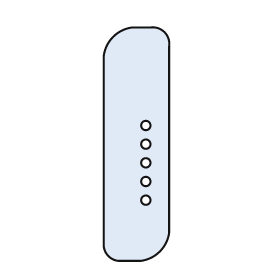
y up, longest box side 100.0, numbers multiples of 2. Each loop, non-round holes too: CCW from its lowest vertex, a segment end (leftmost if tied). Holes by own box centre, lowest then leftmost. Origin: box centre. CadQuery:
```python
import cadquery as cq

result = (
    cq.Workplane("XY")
    .moveTo(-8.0, -50.0)
    .lineTo(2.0, -50.0)
    .threePointArc((10.0, -46.0), (14.0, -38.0))
    .lineTo(14.0, 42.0)
    .threePointArc((12.0, 48.0), (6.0, 50.0))
    .lineTo(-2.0, 50.0)
    .threePointArc((-10.0, 46.0), (-14.0, 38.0))
    .lineTo(-14.0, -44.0)
    .threePointArc((-12.0, -48.0), (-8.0, -50.0))
    .close()
    .moveTo(4.0, -24.0)
    .circle(2.0)
    .moveTo(4.0, -16.0)
    .circle(2.0)
    .moveTo(4.0, -8.0)
    .circle(2.0)
    .moveTo(4.0, 0.0)
    .circle(2.0)
    .moveTo(4.0, 8.0)
    .circle(2.0)
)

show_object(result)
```